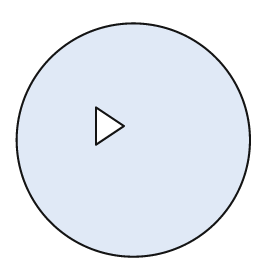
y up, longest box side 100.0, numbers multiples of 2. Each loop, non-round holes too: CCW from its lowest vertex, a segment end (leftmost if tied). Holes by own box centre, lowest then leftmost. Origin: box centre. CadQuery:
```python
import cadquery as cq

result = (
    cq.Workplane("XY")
    .moveTo(0.0, 0.0)
    .circle(50.0)
    .moveTo(-16.0, -2.0)
    .lineTo(-4.0, 6.0)
    .lineTo(-16.0, 14.0)
    .close()
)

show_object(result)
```